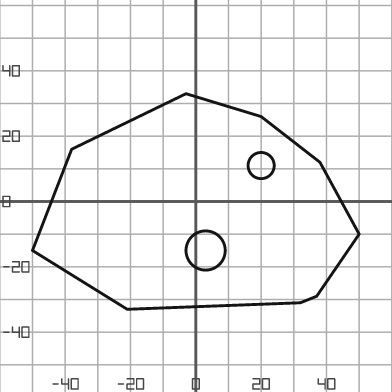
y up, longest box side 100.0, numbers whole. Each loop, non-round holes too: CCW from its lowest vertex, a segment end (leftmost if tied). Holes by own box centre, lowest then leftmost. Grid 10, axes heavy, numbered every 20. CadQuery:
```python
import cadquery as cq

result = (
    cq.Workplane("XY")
    .moveTo(-21.0, -33.0)
    .lineTo(32.0, -31.0)
    .lineTo(37.0, -29.0)
    .lineTo(50.0, -10.0)
    .lineTo(38.0, 12.0)
    .lineTo(20.0, 26.0)
    .lineTo(-3.0, 33.0)
    .lineTo(-38.0, 16.0)
    .lineTo(-50.0, -15.0)
    .close()
    .moveTo(3.0, -15.0)
    .circle(6.0)
    .moveTo(20.0, 11.0)
    .circle(4.0)
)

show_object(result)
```